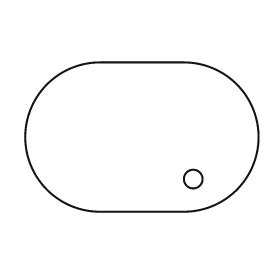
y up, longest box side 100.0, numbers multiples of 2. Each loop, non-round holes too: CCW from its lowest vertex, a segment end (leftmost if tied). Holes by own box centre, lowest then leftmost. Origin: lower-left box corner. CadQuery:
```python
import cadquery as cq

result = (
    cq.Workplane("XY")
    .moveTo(32.0, 0.0)
    .lineTo(68.0, 0.0)
    .threePointArc((100.0, 32.0), (68.0, 64.0))
    .lineTo(32.0, 64.0)
    .threePointArc((0.0, 32.0), (32.0, 0.0))
    .close()
    .moveTo(72.0, 14.0)
    .circle(4.0)
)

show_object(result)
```